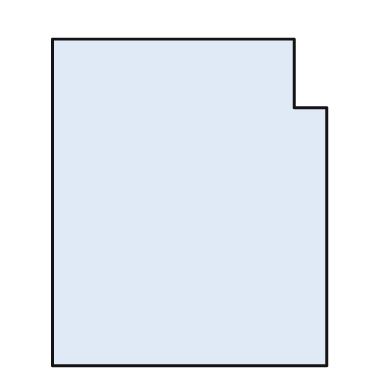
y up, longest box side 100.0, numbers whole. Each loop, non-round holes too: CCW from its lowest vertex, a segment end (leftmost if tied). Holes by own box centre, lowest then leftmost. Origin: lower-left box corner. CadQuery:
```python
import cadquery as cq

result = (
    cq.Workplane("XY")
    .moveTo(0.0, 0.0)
    .lineTo(84.0, 0.0)
    .lineTo(84.0, 79.0)
    .lineTo(74.0, 79.0)
    .lineTo(74.0, 100.0)
    .lineTo(0.0, 100.0)
    .close()
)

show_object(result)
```